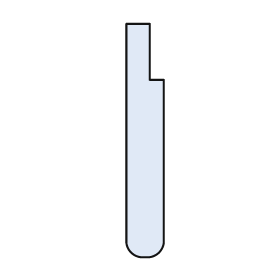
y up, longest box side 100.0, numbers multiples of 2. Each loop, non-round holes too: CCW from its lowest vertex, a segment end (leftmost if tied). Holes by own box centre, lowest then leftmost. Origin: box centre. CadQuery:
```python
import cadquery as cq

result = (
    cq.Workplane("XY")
    .moveTo(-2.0, -50.0)
    .lineTo(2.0, -50.0)
    .threePointArc((6.0, -48.0), (8.0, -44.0))
    .lineTo(8.0, 26.0)
    .lineTo(2.0, 26.0)
    .lineTo(2.0, 50.0)
    .lineTo(-8.0, 50.0)
    .lineTo(-8.0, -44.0)
    .threePointArc((-6.0, -48.0), (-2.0, -50.0))
    .close()
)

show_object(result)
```